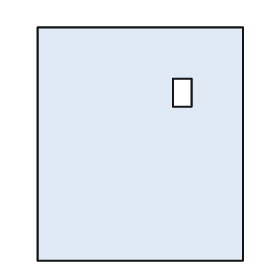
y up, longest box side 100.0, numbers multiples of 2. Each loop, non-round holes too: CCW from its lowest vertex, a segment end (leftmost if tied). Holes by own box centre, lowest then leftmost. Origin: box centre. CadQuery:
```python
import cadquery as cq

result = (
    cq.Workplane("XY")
    .moveTo(-44.0, -50.0)
    .lineTo(44.0, -50.0)
    .lineTo(44.0, 50.0)
    .lineTo(-44.0, 50.0)
    .close()
    .moveTo(14.0, 16.0)
    .lineTo(22.0, 16.0)
    .lineTo(22.0, 28.0)
    .lineTo(14.0, 28.0)
    .close()
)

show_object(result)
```